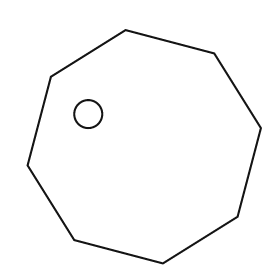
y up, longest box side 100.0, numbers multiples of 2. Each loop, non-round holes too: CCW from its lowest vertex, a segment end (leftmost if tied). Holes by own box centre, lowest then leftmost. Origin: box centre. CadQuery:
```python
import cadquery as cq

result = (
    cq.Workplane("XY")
    .moveTo(8.0, -50.0)
    .lineTo(40.0, -30.0)
    .lineTo(50.0, 8.0)
    .lineTo(30.0, 40.0)
    .lineTo(-8.0, 50.0)
    .lineTo(-40.0, 30.0)
    .lineTo(-50.0, -8.0)
    .lineTo(-30.0, -40.0)
    .close()
    .moveTo(-24.0, 14.0)
    .circle(6.0)
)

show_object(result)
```